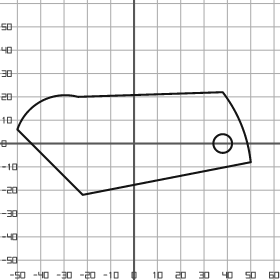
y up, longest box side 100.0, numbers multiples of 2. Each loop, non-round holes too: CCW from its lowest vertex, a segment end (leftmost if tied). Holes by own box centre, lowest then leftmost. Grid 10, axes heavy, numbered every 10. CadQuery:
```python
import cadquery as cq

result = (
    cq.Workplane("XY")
    .moveTo(-22.0, -22.0)
    .lineTo(50.0, -8.0)
    .threePointArc((46.0, 8.0), (38.0, 22.0))
    .lineTo(-24.0, 20.0)
    .threePointArc((-40.0, 18.0), (-50.0, 6.0))
    .close()
    .moveTo(38.0, 0.0)
    .circle(4.0)
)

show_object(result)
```